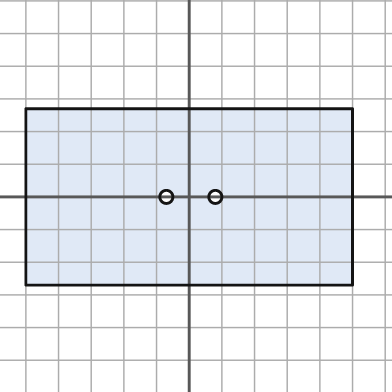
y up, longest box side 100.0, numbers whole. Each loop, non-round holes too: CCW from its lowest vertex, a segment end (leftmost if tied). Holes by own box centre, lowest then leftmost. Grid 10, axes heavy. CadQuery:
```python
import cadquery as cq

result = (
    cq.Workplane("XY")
    .moveTo(-50.0, -27.0)
    .lineTo(50.0, -27.0)
    .lineTo(50.0, 27.0)
    .lineTo(-50.0, 27.0)
    .close()
    .moveTo(-7.0, 0.0)
    .circle(2.0)
    .moveTo(8.0, 0.0)
    .circle(2.0)
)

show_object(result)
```